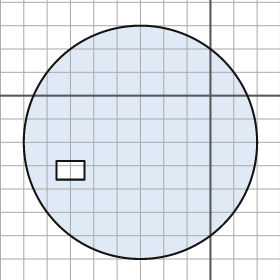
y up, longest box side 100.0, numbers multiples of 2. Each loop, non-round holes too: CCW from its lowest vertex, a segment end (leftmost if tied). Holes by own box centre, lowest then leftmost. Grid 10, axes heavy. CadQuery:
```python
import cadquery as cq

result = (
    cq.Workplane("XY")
    .moveTo(-30.0, -20.0)
    .circle(50.0)
    .moveTo(-66.0, -36.0)
    .lineTo(-54.0, -36.0)
    .lineTo(-54.0, -28.0)
    .lineTo(-66.0, -28.0)
    .close()
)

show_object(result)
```